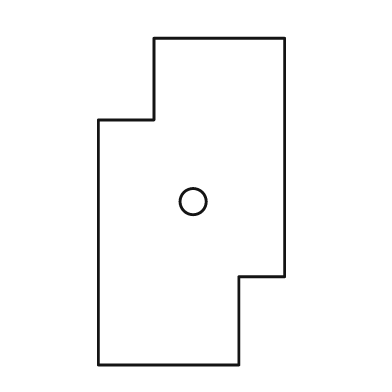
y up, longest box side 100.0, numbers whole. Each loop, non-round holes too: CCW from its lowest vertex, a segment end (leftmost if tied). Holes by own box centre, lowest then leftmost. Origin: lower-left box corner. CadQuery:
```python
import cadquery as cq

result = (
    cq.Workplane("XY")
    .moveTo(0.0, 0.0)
    .lineTo(43.0, 0.0)
    .lineTo(43.0, 27.0)
    .lineTo(57.0, 27.0)
    .lineTo(57.0, 100.0)
    .lineTo(17.0, 100.0)
    .lineTo(17.0, 75.0)
    .lineTo(0.0, 75.0)
    .close()
    .moveTo(29.0, 50.0)
    .circle(4.0)
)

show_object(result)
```